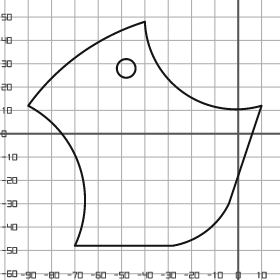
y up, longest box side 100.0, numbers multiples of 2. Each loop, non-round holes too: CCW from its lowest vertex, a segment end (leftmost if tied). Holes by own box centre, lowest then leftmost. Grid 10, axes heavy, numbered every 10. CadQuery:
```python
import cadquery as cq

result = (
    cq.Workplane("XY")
    .moveTo(-70.0, -48.0)
    .lineTo(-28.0, -48.0)
    .threePointArc((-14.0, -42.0), (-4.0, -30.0))
    .lineTo(10.0, 12.0)
    .threePointArc((-24.0, 18.0), (-40.0, 48.0))
    .threePointArc((-68.0, 34.0), (-90.0, 12.0))
    .threePointArc((-68.0, -14.0), (-70.0, -48.0))
    .close()
    .moveTo(-48.0, 28.0)
    .circle(4.0)
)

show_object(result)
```